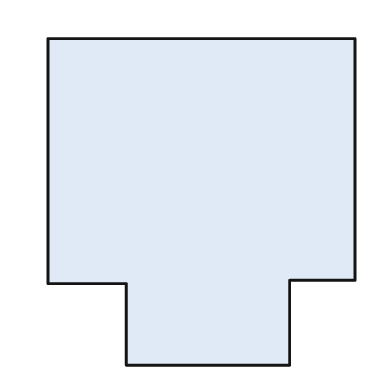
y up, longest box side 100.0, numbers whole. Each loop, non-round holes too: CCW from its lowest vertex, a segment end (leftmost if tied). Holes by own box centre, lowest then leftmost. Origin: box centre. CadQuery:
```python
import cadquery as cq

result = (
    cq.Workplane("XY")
    .moveTo(-23.0, -50.0)
    .lineTo(27.0, -50.0)
    .lineTo(27.0, -24.0)
    .lineTo(47.0, -24.0)
    .lineTo(47.0, 50.0)
    .lineTo(-47.0, 50.0)
    .lineTo(-47.0, -25.0)
    .lineTo(-23.0, -25.0)
    .close()
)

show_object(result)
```